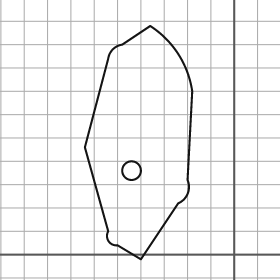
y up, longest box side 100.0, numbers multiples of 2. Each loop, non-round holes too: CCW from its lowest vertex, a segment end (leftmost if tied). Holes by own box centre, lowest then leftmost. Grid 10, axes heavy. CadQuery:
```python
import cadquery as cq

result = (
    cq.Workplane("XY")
    .moveTo(-40.0, -2.0)
    .lineTo(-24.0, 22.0)
    .threePointArc((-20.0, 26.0), (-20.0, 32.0))
    .lineTo(-18.0, 70.0)
    .threePointArc((-24.0, 86.0), (-36.0, 98.0))
    .lineTo(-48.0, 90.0)
    .threePointArc((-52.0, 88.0), (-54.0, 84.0))
    .lineTo(-64.0, 46.0)
    .lineTo(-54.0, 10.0)
    .threePointArc((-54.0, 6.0), (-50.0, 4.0))
    .close()
    .moveTo(-44.0, 36.0)
    .circle(4.0)
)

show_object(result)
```